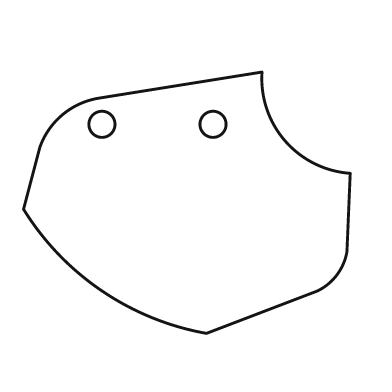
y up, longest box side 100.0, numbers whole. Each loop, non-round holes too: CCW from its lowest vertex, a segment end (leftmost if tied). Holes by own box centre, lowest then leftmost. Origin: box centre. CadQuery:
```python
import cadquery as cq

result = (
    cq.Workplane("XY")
    .moveTo(6.0, -40.0)
    .lineTo(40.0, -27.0)
    .threePointArc((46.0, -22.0), (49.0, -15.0))
    .lineTo(50.0, 9.0)
    .threePointArc((30.0, 19.0), (23.0, 40.0))
    .lineTo(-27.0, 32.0)
    .threePointArc((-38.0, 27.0), (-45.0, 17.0))
    .lineTo(-50.0, -2.0)
    .threePointArc((-26.0, -27.0), (6.0, -40.0))
    .close()
    .moveTo(-26.0, 24.0)
    .circle(4.0)
    .moveTo(8.0, 24.0)
    .circle(4.0)
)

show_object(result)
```